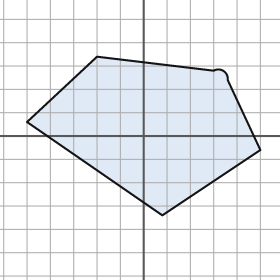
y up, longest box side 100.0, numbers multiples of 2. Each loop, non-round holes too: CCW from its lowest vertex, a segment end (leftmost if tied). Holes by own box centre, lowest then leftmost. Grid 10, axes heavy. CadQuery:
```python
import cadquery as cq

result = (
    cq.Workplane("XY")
    .moveTo(8.0, -34.0)
    .lineTo(50.0, -6.0)
    .lineTo(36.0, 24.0)
    .threePointArc((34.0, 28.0), (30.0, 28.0))
    .lineTo(-20.0, 34.0)
    .lineTo(-50.0, 6.0)
    .close()
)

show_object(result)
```